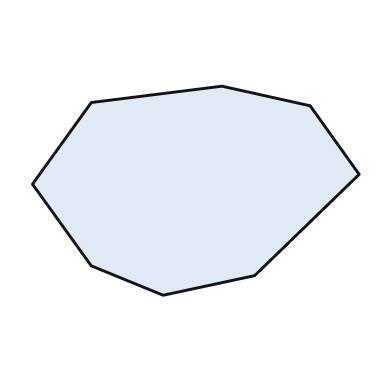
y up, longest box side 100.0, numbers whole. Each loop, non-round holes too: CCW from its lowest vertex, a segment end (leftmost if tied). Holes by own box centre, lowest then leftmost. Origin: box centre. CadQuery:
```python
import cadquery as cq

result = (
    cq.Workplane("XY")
    .moveTo(-10.0, -32.0)
    .lineTo(18.0, -26.0)
    .lineTo(50.0, 5.0)
    .lineTo(35.0, 26.0)
    .lineTo(8.0, 32.0)
    .lineTo(-32.0, 27.0)
    .lineTo(-50.0, 2.0)
    .lineTo(-32.0, -23.0)
    .close()
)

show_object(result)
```